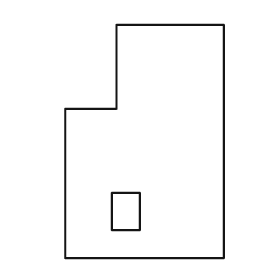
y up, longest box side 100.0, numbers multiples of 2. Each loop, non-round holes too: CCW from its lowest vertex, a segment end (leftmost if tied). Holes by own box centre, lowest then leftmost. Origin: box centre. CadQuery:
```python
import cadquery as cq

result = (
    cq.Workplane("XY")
    .moveTo(-34.0, -50.0)
    .lineTo(34.0, -50.0)
    .lineTo(34.0, 50.0)
    .lineTo(-12.0, 50.0)
    .lineTo(-12.0, 14.0)
    .lineTo(-34.0, 14.0)
    .close()
    .moveTo(-14.0, -38.0)
    .lineTo(-2.0, -38.0)
    .lineTo(-2.0, -22.0)
    .lineTo(-14.0, -22.0)
    .close()
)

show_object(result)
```